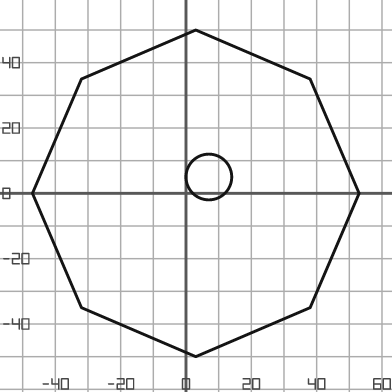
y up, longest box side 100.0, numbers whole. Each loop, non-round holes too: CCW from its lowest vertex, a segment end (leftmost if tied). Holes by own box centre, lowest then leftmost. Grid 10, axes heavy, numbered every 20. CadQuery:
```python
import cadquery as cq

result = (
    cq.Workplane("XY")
    .moveTo(3.0, -50.0)
    .lineTo(38.0, -35.0)
    .lineTo(53.0, 0.0)
    .lineTo(38.0, 35.0)
    .lineTo(3.0, 50.0)
    .lineTo(-32.0, 35.0)
    .lineTo(-47.0, 0.0)
    .lineTo(-32.0, -35.0)
    .close()
    .moveTo(7.0, 5.0)
    .circle(7.0)
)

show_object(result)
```